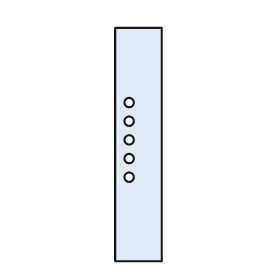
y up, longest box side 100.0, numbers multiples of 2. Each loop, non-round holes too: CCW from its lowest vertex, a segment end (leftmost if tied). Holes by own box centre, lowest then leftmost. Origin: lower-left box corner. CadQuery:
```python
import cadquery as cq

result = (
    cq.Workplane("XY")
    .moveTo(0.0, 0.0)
    .lineTo(20.0, 0.0)
    .lineTo(20.0, 100.0)
    .lineTo(0.0, 100.0)
    .close()
    .moveTo(6.0, 36.0)
    .circle(2.0)
    .moveTo(6.0, 44.0)
    .circle(2.0)
    .moveTo(6.0, 52.0)
    .circle(2.0)
    .moveTo(6.0, 60.0)
    .circle(2.0)
    .moveTo(6.0, 68.0)
    .circle(2.0)
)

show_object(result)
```